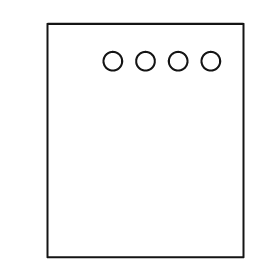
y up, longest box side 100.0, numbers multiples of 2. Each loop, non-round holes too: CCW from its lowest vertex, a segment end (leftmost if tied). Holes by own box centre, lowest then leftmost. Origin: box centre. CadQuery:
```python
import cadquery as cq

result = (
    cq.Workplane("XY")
    .moveTo(-42.0, -50.0)
    .lineTo(42.0, -50.0)
    .lineTo(42.0, 50.0)
    .lineTo(-42.0, 50.0)
    .close()
    .moveTo(-14.0, 34.0)
    .circle(4.0)
    .moveTo(0.0, 34.0)
    .circle(4.0)
    .moveTo(14.0, 34.0)
    .circle(4.0)
    .moveTo(28.0, 34.0)
    .circle(4.0)
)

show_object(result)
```